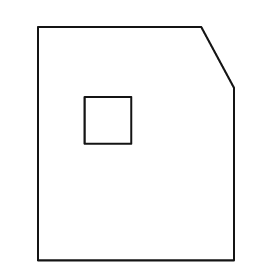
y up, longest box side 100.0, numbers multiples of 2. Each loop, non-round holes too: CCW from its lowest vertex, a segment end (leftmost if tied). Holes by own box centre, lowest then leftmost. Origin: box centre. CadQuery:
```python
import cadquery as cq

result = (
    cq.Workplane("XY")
    .moveTo(-42.0, -50.0)
    .lineTo(42.0, -50.0)
    .lineTo(42.0, 24.0)
    .lineTo(28.0, 50.0)
    .lineTo(-42.0, 50.0)
    .close()
    .moveTo(-22.0, 0.0)
    .lineTo(-2.0, 0.0)
    .lineTo(-2.0, 20.0)
    .lineTo(-22.0, 20.0)
    .close()
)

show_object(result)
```